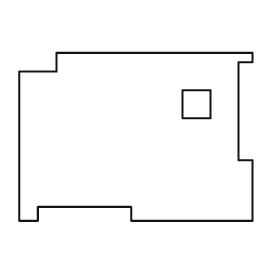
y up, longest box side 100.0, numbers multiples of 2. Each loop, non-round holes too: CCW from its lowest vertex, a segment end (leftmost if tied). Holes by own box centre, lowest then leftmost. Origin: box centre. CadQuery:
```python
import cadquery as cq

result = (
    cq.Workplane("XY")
    .moveTo(-50.0, -36.0)
    .lineTo(-42.0, -36.0)
    .lineTo(-42.0, -30.0)
    .lineTo(-2.0, -30.0)
    .lineTo(-2.0, -36.0)
    .lineTo(50.0, -36.0)
    .lineTo(50.0, -10.0)
    .lineTo(44.0, -10.0)
    .lineTo(44.0, 32.0)
    .lineTo(50.0, 32.0)
    .lineTo(50.0, 36.0)
    .lineTo(-34.0, 36.0)
    .lineTo(-34.0, 28.0)
    .lineTo(-50.0, 28.0)
    .close()
    .moveTo(20.0, 8.0)
    .lineTo(32.0, 8.0)
    .lineTo(32.0, 20.0)
    .lineTo(20.0, 20.0)
    .close()
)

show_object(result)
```